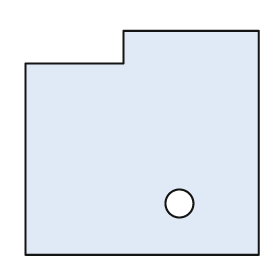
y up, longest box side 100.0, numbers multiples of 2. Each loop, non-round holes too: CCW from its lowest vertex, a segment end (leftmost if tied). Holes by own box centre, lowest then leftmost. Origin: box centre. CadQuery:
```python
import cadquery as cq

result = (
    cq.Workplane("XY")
    .moveTo(-50.0, -48.0)
    .lineTo(50.0, -48.0)
    .lineTo(50.0, 48.0)
    .lineTo(-8.0, 48.0)
    .lineTo(-8.0, 34.0)
    .lineTo(-50.0, 34.0)
    .close()
    .moveTo(16.0, -26.0)
    .circle(6.0)
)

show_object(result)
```